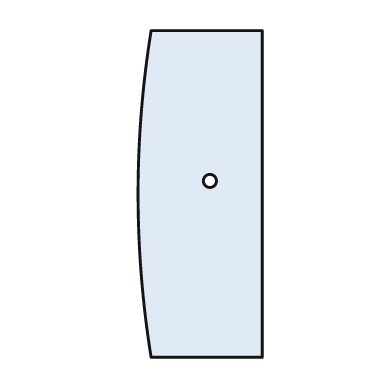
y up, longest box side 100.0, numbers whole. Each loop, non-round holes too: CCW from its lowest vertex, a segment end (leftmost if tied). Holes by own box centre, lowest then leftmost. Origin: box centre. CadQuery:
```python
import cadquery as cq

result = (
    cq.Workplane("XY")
    .moveTo(-15.0, -50.0)
    .lineTo(19.0, -50.0)
    .lineTo(19.0, 50.0)
    .lineTo(-15.0, 50.0)
    .threePointArc((-19.0, 0.0), (-15.0, -50.0))
    .close()
    .moveTo(3.0, 4.0)
    .circle(2.0)
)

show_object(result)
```